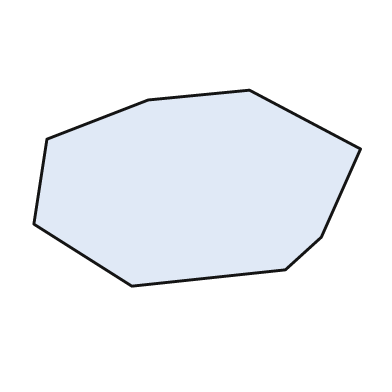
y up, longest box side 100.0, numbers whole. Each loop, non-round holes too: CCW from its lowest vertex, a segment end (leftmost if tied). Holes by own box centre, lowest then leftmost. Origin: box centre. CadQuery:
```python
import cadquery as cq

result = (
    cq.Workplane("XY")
    .moveTo(-20.0, -30.0)
    .lineTo(27.0, -25.0)
    .lineTo(38.0, -15.0)
    .lineTo(50.0, 12.0)
    .lineTo(16.0, 30.0)
    .lineTo(-15.0, 27.0)
    .lineTo(-46.0, 15.0)
    .lineTo(-50.0, -11.0)
    .close()
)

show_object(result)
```